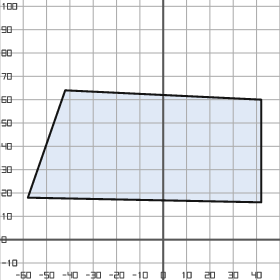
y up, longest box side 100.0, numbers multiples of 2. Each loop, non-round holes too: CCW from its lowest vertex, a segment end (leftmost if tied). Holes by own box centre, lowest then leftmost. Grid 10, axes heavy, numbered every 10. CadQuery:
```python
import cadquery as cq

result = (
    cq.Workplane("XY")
    .moveTo(42.0, 16.0)
    .lineTo(42.0, 60.0)
    .lineTo(-42.0, 64.0)
    .lineTo(-58.0, 18.0)
    .close()
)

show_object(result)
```